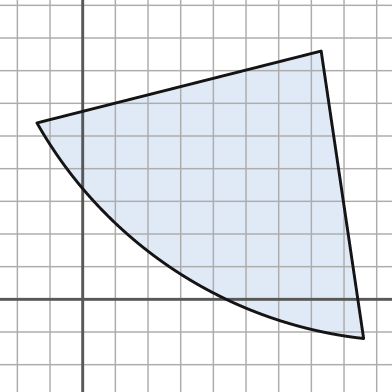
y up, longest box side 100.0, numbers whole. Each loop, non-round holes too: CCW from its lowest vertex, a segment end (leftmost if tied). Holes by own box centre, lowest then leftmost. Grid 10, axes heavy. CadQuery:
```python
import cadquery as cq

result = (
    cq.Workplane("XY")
    .moveTo(86.0, -12.0)
    .lineTo(73.0, 76.0)
    .lineTo(-14.0, 54.0)
    .threePointArc((28.0, 9.0), (86.0, -12.0))
    .close()
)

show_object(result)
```